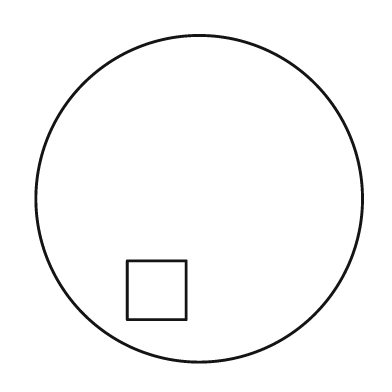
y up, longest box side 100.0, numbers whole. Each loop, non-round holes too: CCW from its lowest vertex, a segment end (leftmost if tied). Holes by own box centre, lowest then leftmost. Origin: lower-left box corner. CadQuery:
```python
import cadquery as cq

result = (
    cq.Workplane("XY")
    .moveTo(50.0, 50.0)
    .circle(50.0)
    .moveTo(28.0, 13.0)
    .lineTo(46.0, 13.0)
    .lineTo(46.0, 31.0)
    .lineTo(28.0, 31.0)
    .close()
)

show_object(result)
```